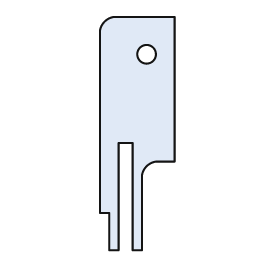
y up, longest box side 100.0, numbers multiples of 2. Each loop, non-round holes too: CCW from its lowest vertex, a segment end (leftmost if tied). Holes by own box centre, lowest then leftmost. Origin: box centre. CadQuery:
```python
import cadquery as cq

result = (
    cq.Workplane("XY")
    .moveTo(-12.0, -50.0)
    .lineTo(-8.0, -50.0)
    .lineTo(-8.0, -4.0)
    .lineTo(-2.0, -4.0)
    .lineTo(-2.0, -50.0)
    .lineTo(2.0, -50.0)
    .lineTo(2.0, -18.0)
    .threePointArc((4.0, -14.0), (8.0, -12.0))
    .lineTo(16.0, -12.0)
    .lineTo(16.0, 50.0)
    .lineTo(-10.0, 50.0)
    .threePointArc((-14.0, 48.0), (-16.0, 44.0))
    .lineTo(-16.0, -34.0)
    .lineTo(-12.0, -34.0)
    .close()
    .moveTo(4.0, 34.0)
    .circle(4.0)
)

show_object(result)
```